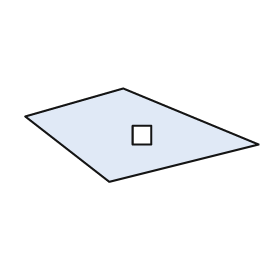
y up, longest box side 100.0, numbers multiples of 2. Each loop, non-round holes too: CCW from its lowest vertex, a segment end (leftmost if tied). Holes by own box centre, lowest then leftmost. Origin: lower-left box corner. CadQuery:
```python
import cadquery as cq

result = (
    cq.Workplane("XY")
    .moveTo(36.0, 0.0)
    .lineTo(100.0, 16.0)
    .lineTo(42.0, 40.0)
    .lineTo(0.0, 28.0)
    .close()
    .moveTo(46.0, 16.0)
    .lineTo(54.0, 16.0)
    .lineTo(54.0, 24.0)
    .lineTo(46.0, 24.0)
    .close()
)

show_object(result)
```